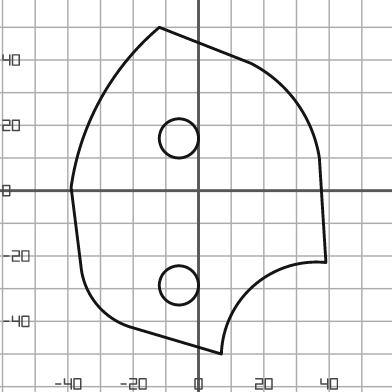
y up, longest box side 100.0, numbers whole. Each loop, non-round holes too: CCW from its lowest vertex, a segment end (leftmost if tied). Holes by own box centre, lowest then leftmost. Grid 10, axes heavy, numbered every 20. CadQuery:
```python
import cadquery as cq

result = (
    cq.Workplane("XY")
    .moveTo(7.0, -50.0)
    .threePointArc((17.0, -29.0), (39.0, -22.0))
    .lineTo(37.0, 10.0)
    .threePointArc((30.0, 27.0), (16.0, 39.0))
    .lineTo(-12.0, 50.0)
    .threePointArc((-30.0, 28.0), (-39.0, 1.0))
    .lineTo(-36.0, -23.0)
    .threePointArc((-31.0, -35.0), (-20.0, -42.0))
    .close()
    .moveTo(-6.0, -29.0)
    .circle(6.0)
    .moveTo(-6.0, 16.0)
    .circle(6.0)
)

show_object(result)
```